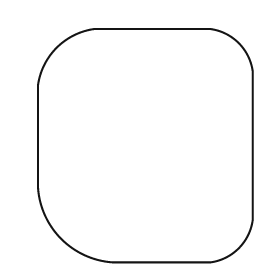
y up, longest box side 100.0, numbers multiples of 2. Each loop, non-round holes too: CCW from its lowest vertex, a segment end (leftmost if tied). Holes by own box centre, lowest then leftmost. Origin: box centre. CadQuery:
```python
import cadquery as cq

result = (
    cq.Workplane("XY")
    .moveTo(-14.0, -50.0)
    .lineTo(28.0, -50.0)
    .threePointArc((40.0, -44.0), (46.0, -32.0))
    .lineTo(46.0, 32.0)
    .threePointArc((40.0, 44.0), (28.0, 50.0))
    .lineTo(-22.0, 50.0)
    .threePointArc((-38.0, 42.0), (-46.0, 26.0))
    .lineTo(-46.0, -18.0)
    .threePointArc((-36.0, -40.0), (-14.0, -50.0))
    .close()
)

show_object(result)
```